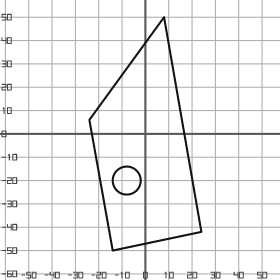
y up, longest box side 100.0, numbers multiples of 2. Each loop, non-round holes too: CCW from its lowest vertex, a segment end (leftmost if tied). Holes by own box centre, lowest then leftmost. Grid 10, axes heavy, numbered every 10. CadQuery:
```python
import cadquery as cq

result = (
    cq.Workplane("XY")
    .moveTo(-14.0, -50.0)
    .lineTo(24.0, -42.0)
    .lineTo(8.0, 50.0)
    .lineTo(-24.0, 6.0)
    .close()
    .moveTo(-8.0, -20.0)
    .circle(6.0)
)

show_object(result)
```